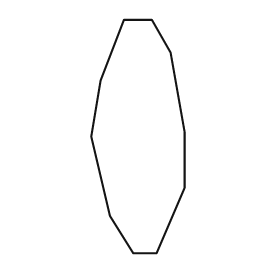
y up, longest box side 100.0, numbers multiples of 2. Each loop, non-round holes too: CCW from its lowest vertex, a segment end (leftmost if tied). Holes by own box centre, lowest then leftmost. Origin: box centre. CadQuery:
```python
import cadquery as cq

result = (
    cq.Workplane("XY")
    .moveTo(-2.0, -50.0)
    .lineTo(8.0, -50.0)
    .lineTo(20.0, -22.0)
    .lineTo(20.0, 2.0)
    .lineTo(14.0, 36.0)
    .lineTo(6.0, 50.0)
    .lineTo(-6.0, 50.0)
    .lineTo(-16.0, 24.0)
    .lineTo(-20.0, 0.0)
    .lineTo(-12.0, -34.0)
    .close()
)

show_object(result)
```